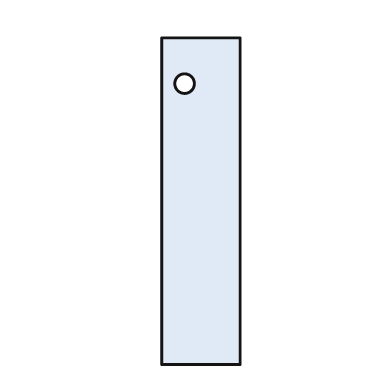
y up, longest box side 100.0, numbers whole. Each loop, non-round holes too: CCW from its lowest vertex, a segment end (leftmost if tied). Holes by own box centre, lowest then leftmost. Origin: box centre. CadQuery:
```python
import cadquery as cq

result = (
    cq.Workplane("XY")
    .moveTo(-12.0, -50.0)
    .lineTo(12.0, -50.0)
    .lineTo(12.0, 50.0)
    .lineTo(-12.0, 50.0)
    .close()
    .moveTo(-5.0, 36.0)
    .circle(3.0)
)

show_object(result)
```